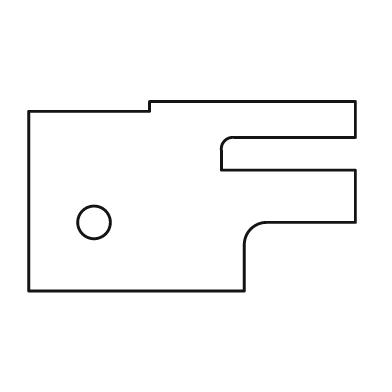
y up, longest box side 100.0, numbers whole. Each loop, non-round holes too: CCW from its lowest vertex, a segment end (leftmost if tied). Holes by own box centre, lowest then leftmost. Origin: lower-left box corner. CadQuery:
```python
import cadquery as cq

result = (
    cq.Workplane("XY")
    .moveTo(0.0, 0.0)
    .lineTo(66.0, 0.0)
    .lineTo(66.0, 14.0)
    .threePointArc((68.0, 19.0), (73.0, 21.0))
    .lineTo(100.0, 21.0)
    .lineTo(100.0, 37.0)
    .lineTo(59.0, 37.0)
    .lineTo(59.0, 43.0)
    .threePointArc((60.0, 46.0), (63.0, 47.0))
    .lineTo(100.0, 47.0)
    .lineTo(100.0, 58.0)
    .lineTo(37.0, 58.0)
    .lineTo(37.0, 55.0)
    .lineTo(0.0, 55.0)
    .close()
    .moveTo(20.0, 21.0)
    .circle(5.0)
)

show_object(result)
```